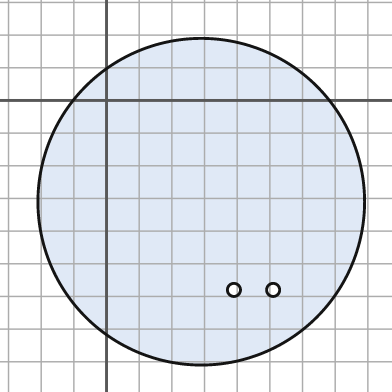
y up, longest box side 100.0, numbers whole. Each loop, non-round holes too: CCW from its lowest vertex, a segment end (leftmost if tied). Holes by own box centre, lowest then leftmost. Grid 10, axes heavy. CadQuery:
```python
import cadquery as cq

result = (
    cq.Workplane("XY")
    .moveTo(29.0, -31.0)
    .circle(50.0)
    .moveTo(39.0, -58.0)
    .circle(2.0)
    .moveTo(51.0, -58.0)
    .circle(2.0)
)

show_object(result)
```